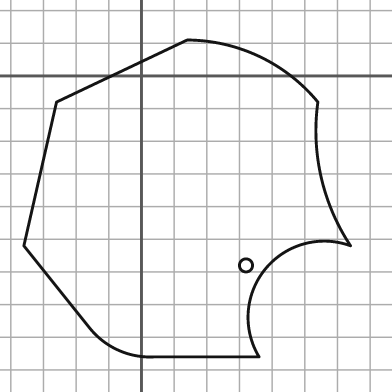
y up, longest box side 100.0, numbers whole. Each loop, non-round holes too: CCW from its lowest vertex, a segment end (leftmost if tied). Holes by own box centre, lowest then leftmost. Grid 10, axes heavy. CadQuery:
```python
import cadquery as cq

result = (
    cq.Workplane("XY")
    .moveTo(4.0, -86.0)
    .lineTo(36.0, -86.0)
    .threePointArc((38.0, -59.0), (64.0, -52.0))
    .threePointArc((55.0, -31.0), (54.0, -8.0))
    .threePointArc((36.0, 6.0), (14.0, 11.0))
    .lineTo(-26.0, -8.0)
    .lineTo(-36.0, -52.0)
    .lineTo(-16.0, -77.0)
    .threePointArc((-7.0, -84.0), (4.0, -86.0))
    .close()
    .moveTo(32.0, -58.0)
    .circle(2.0)
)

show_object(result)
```